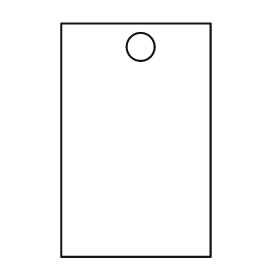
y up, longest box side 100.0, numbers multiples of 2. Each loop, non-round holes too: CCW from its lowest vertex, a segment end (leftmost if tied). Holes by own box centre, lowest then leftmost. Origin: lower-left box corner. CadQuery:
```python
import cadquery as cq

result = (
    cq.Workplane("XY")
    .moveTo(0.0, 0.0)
    .lineTo(64.0, 0.0)
    .lineTo(64.0, 100.0)
    .lineTo(0.0, 100.0)
    .close()
    .moveTo(34.0, 90.0)
    .circle(6.0)
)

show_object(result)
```